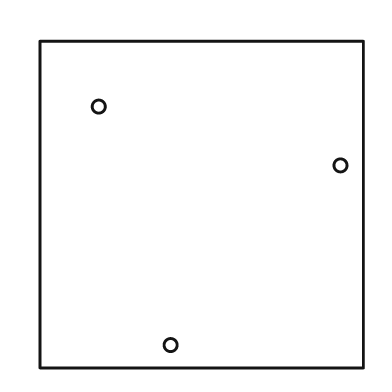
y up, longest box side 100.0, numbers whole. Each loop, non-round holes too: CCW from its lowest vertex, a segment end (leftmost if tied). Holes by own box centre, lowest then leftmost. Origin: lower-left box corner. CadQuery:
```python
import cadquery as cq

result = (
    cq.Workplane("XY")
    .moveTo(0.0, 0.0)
    .lineTo(99.0, 0.0)
    .lineTo(99.0, 100.0)
    .lineTo(0.0, 100.0)
    .close()
    .moveTo(40.0, 7.0)
    .circle(2.0)
    .moveTo(92.0, 62.0)
    .circle(2.0)
    .moveTo(18.0, 80.0)
    .circle(2.0)
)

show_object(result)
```